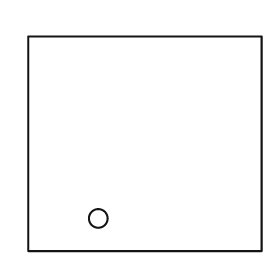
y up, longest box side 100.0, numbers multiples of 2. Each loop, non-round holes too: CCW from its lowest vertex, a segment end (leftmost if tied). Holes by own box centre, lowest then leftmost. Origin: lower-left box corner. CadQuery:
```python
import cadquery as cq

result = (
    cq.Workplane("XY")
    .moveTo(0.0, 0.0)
    .lineTo(100.0, 0.0)
    .lineTo(100.0, 92.0)
    .lineTo(0.0, 92.0)
    .close()
    .moveTo(30.0, 14.0)
    .circle(4.0)
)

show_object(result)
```